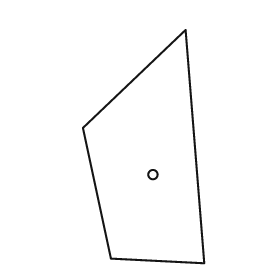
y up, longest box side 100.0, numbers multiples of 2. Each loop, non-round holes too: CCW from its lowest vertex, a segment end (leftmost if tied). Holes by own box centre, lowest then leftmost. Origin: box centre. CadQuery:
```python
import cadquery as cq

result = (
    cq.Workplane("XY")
    .moveTo(26.0, -50.0)
    .lineTo(18.0, 50.0)
    .lineTo(-26.0, 8.0)
    .lineTo(-14.0, -48.0)
    .close()
    .moveTo(4.0, -12.0)
    .circle(2.0)
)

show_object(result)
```